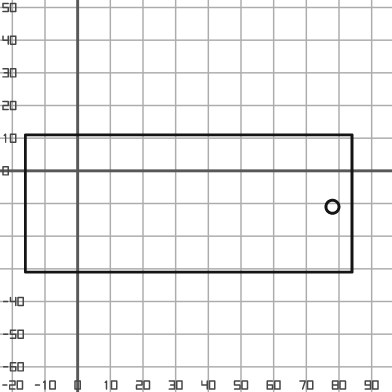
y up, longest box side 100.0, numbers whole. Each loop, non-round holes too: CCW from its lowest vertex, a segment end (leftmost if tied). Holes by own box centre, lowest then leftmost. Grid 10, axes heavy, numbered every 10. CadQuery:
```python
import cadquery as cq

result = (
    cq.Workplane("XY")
    .moveTo(-16.0, -31.0)
    .lineTo(84.0, -31.0)
    .lineTo(84.0, 11.0)
    .lineTo(-16.0, 11.0)
    .close()
    .moveTo(78.0, -11.0)
    .circle(2.0)
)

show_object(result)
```